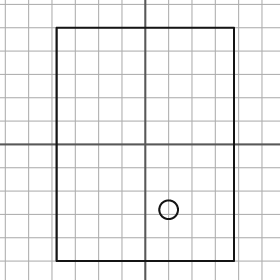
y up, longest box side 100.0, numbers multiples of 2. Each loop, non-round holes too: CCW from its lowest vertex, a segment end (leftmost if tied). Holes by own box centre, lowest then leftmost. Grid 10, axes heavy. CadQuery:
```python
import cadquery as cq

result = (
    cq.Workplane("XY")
    .moveTo(-38.0, -50.0)
    .lineTo(38.0, -50.0)
    .lineTo(38.0, 50.0)
    .lineTo(-38.0, 50.0)
    .close()
    .moveTo(10.0, -28.0)
    .circle(4.0)
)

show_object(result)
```